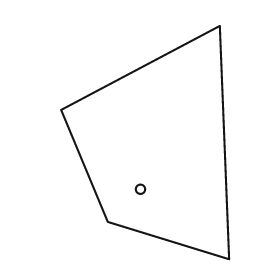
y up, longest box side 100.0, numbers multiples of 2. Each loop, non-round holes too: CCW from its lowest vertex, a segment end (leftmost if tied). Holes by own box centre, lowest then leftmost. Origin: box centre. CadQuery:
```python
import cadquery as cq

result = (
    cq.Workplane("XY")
    .moveTo(36.0, -50.0)
    .lineTo(32.0, 50.0)
    .lineTo(-36.0, 14.0)
    .lineTo(-16.0, -34.0)
    .close()
    .moveTo(-2.0, -20.0)
    .circle(2.0)
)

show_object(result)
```